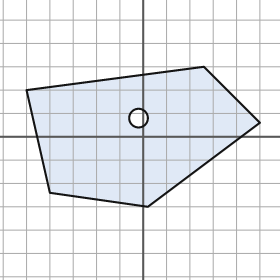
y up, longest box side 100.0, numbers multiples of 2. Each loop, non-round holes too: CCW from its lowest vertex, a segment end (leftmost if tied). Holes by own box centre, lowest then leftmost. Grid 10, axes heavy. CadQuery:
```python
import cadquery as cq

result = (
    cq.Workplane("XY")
    .moveTo(2.0, -30.0)
    .lineTo(50.0, 6.0)
    .lineTo(26.0, 30.0)
    .lineTo(-50.0, 20.0)
    .lineTo(-40.0, -24.0)
    .close()
    .moveTo(-2.0, 8.0)
    .circle(4.0)
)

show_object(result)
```